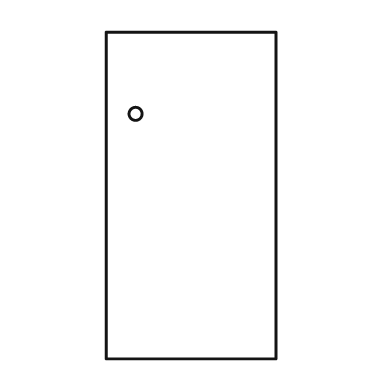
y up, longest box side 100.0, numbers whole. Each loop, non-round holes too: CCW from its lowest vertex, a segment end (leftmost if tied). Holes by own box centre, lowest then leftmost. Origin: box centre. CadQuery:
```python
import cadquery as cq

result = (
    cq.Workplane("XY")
    .moveTo(-26.0, -50.0)
    .lineTo(26.0, -50.0)
    .lineTo(26.0, 50.0)
    .lineTo(-26.0, 50.0)
    .close()
    .moveTo(-17.0, 25.0)
    .circle(2.0)
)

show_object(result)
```